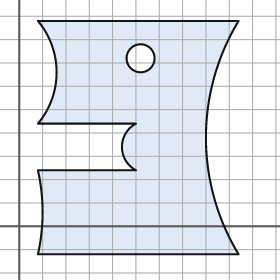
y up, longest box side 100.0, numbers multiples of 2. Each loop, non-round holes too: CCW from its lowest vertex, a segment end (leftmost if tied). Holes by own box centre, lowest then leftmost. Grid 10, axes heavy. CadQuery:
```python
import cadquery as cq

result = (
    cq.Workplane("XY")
    .moveTo(8.0, -12.0)
    .lineTo(94.0, -12.0)
    .threePointArc((80.0, 38.0), (94.0, 88.0))
    .lineTo(8.0, 88.0)
    .threePointArc((16.0, 66.0), (8.0, 44.0))
    .lineTo(50.0, 44.0)
    .threePointArc((44.0, 34.0), (50.0, 24.0))
    .lineTo(8.0, 24.0)
    .threePointArc((10.0, 6.0), (8.0, -12.0))
    .close()
    .moveTo(52.0, 72.0)
    .circle(6.0)
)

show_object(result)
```